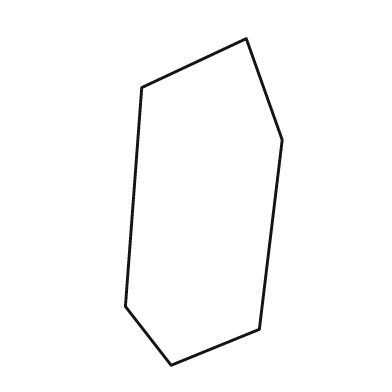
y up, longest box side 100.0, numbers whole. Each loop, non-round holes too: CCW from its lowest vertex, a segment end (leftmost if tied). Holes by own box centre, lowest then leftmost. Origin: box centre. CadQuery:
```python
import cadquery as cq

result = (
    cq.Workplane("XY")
    .moveTo(-10.0, -50.0)
    .lineTo(17.0, -39.0)
    .lineTo(24.0, 19.0)
    .lineTo(13.0, 50.0)
    .lineTo(-19.0, 35.0)
    .lineTo(-24.0, -32.0)
    .close()
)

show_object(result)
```